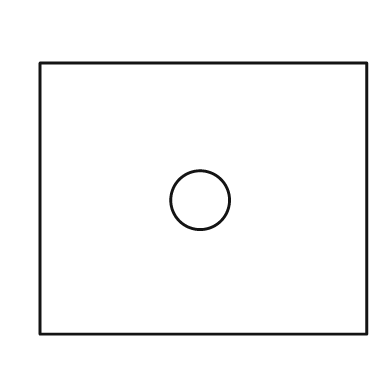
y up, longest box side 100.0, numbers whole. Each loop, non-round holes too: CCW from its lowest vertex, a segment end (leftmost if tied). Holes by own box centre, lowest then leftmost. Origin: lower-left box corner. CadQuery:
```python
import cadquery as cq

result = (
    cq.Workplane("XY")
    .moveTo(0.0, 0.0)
    .lineTo(100.0, 0.0)
    .lineTo(100.0, 83.0)
    .lineTo(0.0, 83.0)
    .close()
    .moveTo(49.0, 41.0)
    .circle(9.0)
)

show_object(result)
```